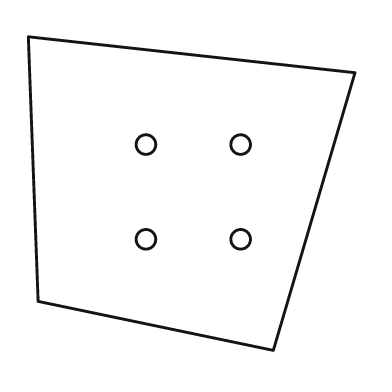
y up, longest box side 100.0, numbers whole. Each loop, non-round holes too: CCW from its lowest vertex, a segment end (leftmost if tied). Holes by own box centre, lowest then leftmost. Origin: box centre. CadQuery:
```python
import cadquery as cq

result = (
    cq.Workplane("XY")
    .moveTo(25.0, -48.0)
    .lineTo(50.0, 37.0)
    .lineTo(-50.0, 48.0)
    .lineTo(-47.0, -33.0)
    .close()
    .moveTo(-14.0, -14.0)
    .circle(3.0)
    .moveTo(15.0, -14.0)
    .circle(3.0)
    .moveTo(-14.0, 15.0)
    .circle(3.0)
    .moveTo(15.0, 15.0)
    .circle(3.0)
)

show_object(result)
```